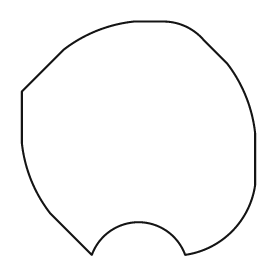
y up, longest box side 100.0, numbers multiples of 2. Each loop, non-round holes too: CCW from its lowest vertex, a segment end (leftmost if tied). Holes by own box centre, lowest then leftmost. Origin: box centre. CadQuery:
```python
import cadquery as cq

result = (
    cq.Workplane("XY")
    .moveTo(-20.0, -50.0)
    .threePointArc((0.0, -36.0), (20.0, -50.0))
    .threePointArc((40.0, -40.0), (50.0, -20.0))
    .lineTo(50.0, 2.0)
    .threePointArc((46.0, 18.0), (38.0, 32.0))
    .lineTo(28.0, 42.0)
    .threePointArc((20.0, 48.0), (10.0, 50.0))
    .lineTo(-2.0, 50.0)
    .threePointArc((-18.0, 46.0), (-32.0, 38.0))
    .lineTo(-50.0, 20.0)
    .lineTo(-50.0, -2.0)
    .threePointArc((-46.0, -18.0), (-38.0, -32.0))
    .close()
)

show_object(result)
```